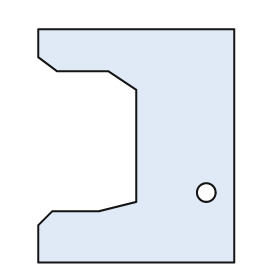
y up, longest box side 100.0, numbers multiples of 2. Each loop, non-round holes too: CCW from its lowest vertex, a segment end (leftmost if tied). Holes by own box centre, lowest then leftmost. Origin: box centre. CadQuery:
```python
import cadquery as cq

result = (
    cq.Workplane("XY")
    .moveTo(-42.0, -50.0)
    .lineTo(42.0, -50.0)
    .lineTo(42.0, 50.0)
    .lineTo(-42.0, 50.0)
    .lineTo(-42.0, 38.0)
    .lineTo(-34.0, 32.0)
    .lineTo(-12.0, 32.0)
    .lineTo(0.0, 24.0)
    .lineTo(0.0, -24.0)
    .lineTo(-16.0, -28.0)
    .lineTo(-36.0, -28.0)
    .lineTo(-42.0, -34.0)
    .close()
    .moveTo(30.0, -20.0)
    .circle(4.0)
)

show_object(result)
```